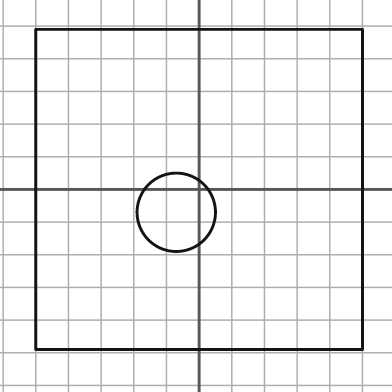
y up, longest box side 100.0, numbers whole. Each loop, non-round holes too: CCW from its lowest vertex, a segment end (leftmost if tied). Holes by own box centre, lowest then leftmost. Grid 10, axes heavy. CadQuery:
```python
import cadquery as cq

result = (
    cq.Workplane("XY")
    .moveTo(-50.0, -49.0)
    .lineTo(50.0, -49.0)
    .lineTo(50.0, 49.0)
    .lineTo(-50.0, 49.0)
    .close()
    .moveTo(-7.0, -7.0)
    .circle(12.0)
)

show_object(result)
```